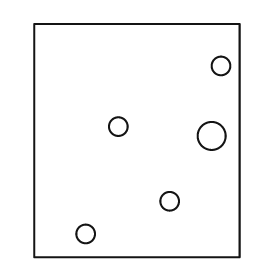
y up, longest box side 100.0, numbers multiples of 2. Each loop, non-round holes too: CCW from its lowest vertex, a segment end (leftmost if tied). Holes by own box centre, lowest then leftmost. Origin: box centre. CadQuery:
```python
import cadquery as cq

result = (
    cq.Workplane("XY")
    .moveTo(-44.0, -50.0)
    .lineTo(44.0, -50.0)
    .lineTo(44.0, 50.0)
    .lineTo(-44.0, 50.0)
    .close()
    .moveTo(-22.0, -40.0)
    .circle(4.0)
    .moveTo(14.0, -26.0)
    .circle(4.0)
    .moveTo(32.0, 2.0)
    .circle(6.0)
    .moveTo(-8.0, 6.0)
    .circle(4.0)
    .moveTo(36.0, 32.0)
    .circle(4.0)
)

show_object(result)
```